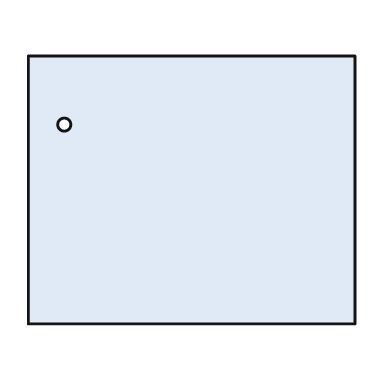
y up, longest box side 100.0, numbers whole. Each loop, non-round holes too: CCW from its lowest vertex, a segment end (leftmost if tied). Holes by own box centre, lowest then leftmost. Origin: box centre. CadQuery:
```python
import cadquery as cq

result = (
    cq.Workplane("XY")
    .moveTo(-50.0, -41.0)
    .lineTo(50.0, -41.0)
    .lineTo(50.0, 41.0)
    .lineTo(-50.0, 41.0)
    .close()
    .moveTo(-39.0, 20.0)
    .circle(2.0)
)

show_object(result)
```